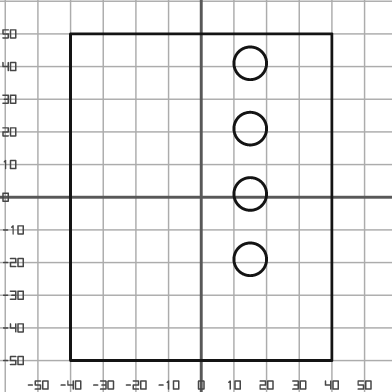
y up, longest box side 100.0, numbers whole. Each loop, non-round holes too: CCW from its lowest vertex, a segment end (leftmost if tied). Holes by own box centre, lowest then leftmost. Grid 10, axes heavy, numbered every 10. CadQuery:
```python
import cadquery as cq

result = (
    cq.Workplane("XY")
    .moveTo(-40.0, -50.0)
    .lineTo(40.0, -50.0)
    .lineTo(40.0, 50.0)
    .lineTo(-40.0, 50.0)
    .close()
    .moveTo(15.0, -19.0)
    .circle(5.0)
    .moveTo(15.0, 1.0)
    .circle(5.0)
    .moveTo(15.0, 21.0)
    .circle(5.0)
    .moveTo(15.0, 41.0)
    .circle(5.0)
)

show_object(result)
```